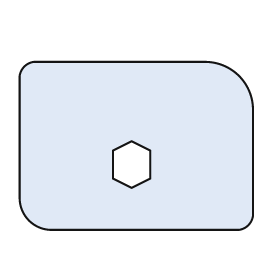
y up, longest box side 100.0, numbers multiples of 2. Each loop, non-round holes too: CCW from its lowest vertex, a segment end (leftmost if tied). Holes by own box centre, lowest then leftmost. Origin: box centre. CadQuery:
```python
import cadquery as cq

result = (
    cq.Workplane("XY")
    .moveTo(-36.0, -36.0)
    .lineTo(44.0, -36.0)
    .threePointArc((48.0, -34.0), (50.0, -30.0))
    .lineTo(50.0, 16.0)
    .threePointArc((44.0, 30.0), (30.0, 36.0))
    .lineTo(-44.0, 36.0)
    .threePointArc((-48.0, 34.0), (-50.0, 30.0))
    .lineTo(-50.0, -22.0)
    .threePointArc((-46.0, -32.0), (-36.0, -36.0))
    .close()
    .moveTo(-2.0, -18.0)
    .lineTo(6.0, -14.0)
    .lineTo(6.0, -2.0)
    .lineTo(-2.0, 2.0)
    .lineTo(-10.0, -2.0)
    .lineTo(-10.0, -14.0)
    .close()
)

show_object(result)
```